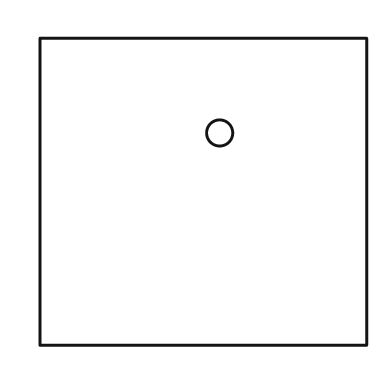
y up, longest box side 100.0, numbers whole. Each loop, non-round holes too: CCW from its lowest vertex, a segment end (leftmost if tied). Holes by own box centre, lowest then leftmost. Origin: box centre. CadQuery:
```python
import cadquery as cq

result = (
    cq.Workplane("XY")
    .moveTo(-50.0, -47.0)
    .lineTo(50.0, -47.0)
    .lineTo(50.0, 47.0)
    .lineTo(-50.0, 47.0)
    .close()
    .moveTo(5.0, 18.0)
    .circle(4.0)
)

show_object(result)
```